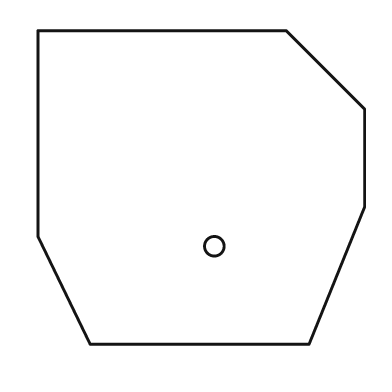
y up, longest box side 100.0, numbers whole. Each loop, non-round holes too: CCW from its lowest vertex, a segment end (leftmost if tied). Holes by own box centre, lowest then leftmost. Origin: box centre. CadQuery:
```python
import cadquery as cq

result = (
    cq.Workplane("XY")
    .moveTo(-34.0, -48.0)
    .lineTo(33.0, -48.0)
    .lineTo(50.0, -6.0)
    .lineTo(50.0, 24.0)
    .lineTo(26.0, 48.0)
    .lineTo(-50.0, 48.0)
    .lineTo(-50.0, -15.0)
    .close()
    .moveTo(4.0, -18.0)
    .circle(3.0)
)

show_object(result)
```